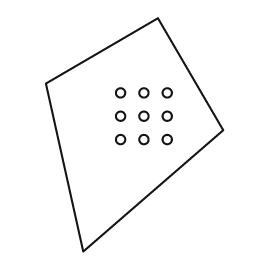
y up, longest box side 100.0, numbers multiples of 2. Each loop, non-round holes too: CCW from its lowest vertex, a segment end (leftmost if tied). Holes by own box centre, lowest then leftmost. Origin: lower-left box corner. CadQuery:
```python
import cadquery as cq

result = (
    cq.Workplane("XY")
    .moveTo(16.0, 0.0)
    .lineTo(76.0, 52.0)
    .lineTo(48.0, 100.0)
    .lineTo(0.0, 72.0)
    .close()
    .moveTo(32.0, 48.0)
    .circle(2.0)
    .moveTo(42.0, 48.0)
    .circle(2.0)
    .moveTo(52.0, 48.0)
    .circle(2.0)
    .moveTo(32.0, 58.0)
    .circle(2.0)
    .moveTo(42.0, 58.0)
    .circle(2.0)
    .moveTo(52.0, 58.0)
    .circle(2.0)
    .moveTo(32.0, 68.0)
    .circle(2.0)
    .moveTo(42.0, 68.0)
    .circle(2.0)
    .moveTo(52.0, 68.0)
    .circle(2.0)
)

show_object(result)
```